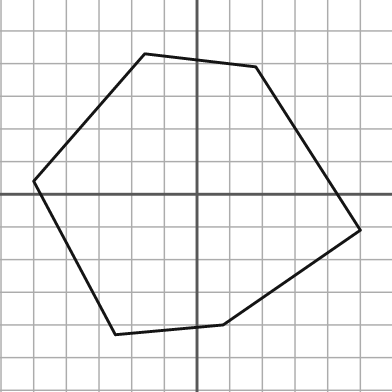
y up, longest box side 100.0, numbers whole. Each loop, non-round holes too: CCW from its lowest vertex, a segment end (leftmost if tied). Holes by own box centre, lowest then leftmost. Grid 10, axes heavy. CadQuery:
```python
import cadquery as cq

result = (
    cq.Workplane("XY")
    .moveTo(-25.0, -43.0)
    .lineTo(8.0, -40.0)
    .lineTo(50.0, -11.0)
    .lineTo(18.0, 39.0)
    .lineTo(-16.0, 43.0)
    .lineTo(-50.0, 4.0)
    .close()
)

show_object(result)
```